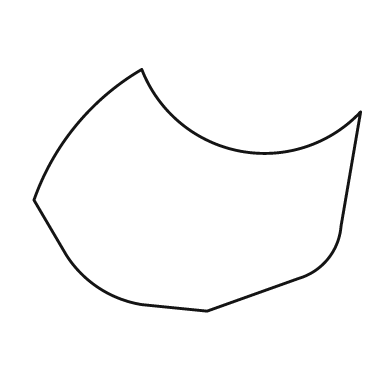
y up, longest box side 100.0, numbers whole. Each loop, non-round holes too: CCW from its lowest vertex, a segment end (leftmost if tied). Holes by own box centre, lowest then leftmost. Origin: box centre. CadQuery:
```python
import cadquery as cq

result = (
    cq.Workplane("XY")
    .moveTo(3.0, -37.0)
    .lineTo(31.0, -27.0)
    .threePointArc((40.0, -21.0), (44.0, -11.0))
    .lineTo(50.0, 24.0)
    .threePointArc((13.0, 12.0), (-17.0, 37.0))
    .threePointArc((-37.0, 20.0), (-50.0, -3.0))
    .lineTo(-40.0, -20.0)
    .threePointArc((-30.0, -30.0), (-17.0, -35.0))
    .close()
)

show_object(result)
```